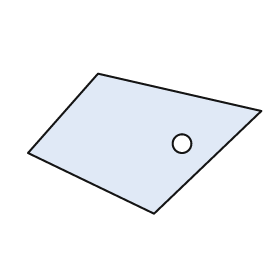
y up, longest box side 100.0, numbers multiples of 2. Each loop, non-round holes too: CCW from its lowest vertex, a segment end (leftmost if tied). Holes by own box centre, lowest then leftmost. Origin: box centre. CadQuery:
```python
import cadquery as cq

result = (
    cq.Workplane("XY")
    .moveTo(4.0, -30.0)
    .lineTo(50.0, 14.0)
    .lineTo(-20.0, 30.0)
    .lineTo(-50.0, -4.0)
    .close()
    .moveTo(16.0, 0.0)
    .circle(4.0)
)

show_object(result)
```